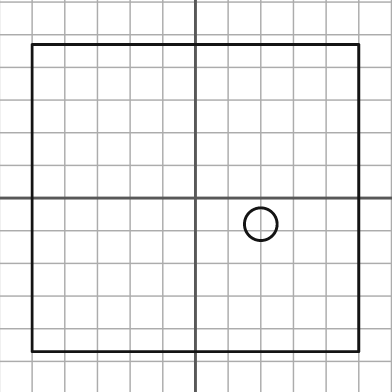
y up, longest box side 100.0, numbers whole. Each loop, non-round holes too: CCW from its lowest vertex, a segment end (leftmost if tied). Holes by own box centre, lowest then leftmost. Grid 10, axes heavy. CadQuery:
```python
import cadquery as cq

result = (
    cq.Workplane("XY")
    .moveTo(-50.0, -47.0)
    .lineTo(50.0, -47.0)
    .lineTo(50.0, 47.0)
    .lineTo(-50.0, 47.0)
    .close()
    .moveTo(20.0, -8.0)
    .circle(5.0)
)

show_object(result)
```